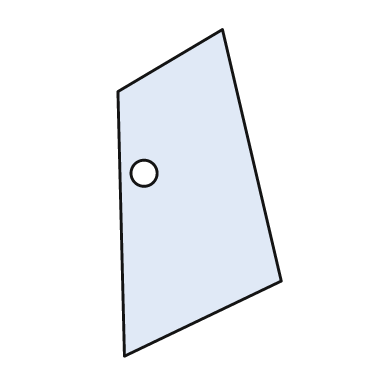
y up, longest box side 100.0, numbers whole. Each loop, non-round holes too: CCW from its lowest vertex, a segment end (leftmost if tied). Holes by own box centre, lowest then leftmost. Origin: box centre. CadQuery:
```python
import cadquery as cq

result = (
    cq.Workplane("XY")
    .moveTo(-23.0, -50.0)
    .lineTo(25.0, -27.0)
    .lineTo(7.0, 50.0)
    .lineTo(-25.0, 31.0)
    .close()
    .moveTo(-17.0, 6.0)
    .circle(4.0)
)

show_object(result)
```